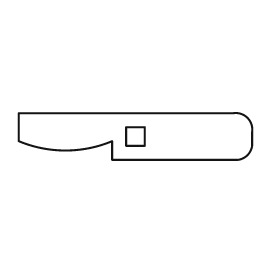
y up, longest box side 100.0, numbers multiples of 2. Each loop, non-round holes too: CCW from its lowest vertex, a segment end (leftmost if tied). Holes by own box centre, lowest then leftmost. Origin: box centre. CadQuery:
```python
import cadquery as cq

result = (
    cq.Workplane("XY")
    .moveTo(-10.0, -10.0)
    .lineTo(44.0, -10.0)
    .threePointArc((48.0, -8.0), (50.0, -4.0))
    .lineTo(50.0, 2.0)
    .threePointArc((48.0, 8.0), (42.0, 10.0))
    .lineTo(-50.0, 10.0)
    .lineTo(-50.0, -2.0)
    .threePointArc((-30.0, -6.0), (-10.0, -2.0))
    .close()
    .moveTo(-4.0, -4.0)
    .lineTo(4.0, -4.0)
    .lineTo(4.0, 4.0)
    .lineTo(-4.0, 4.0)
    .close()
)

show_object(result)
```